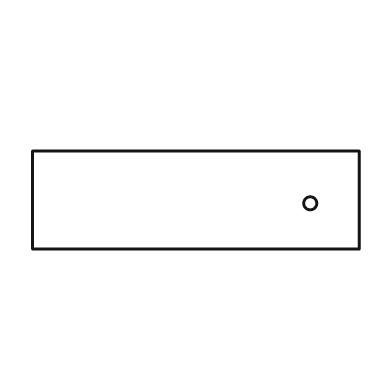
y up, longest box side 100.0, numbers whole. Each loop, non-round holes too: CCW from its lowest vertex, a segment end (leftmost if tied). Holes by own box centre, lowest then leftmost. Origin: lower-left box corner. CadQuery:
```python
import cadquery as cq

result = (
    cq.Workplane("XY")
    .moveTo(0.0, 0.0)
    .lineTo(100.0, 0.0)
    .lineTo(100.0, 30.0)
    .lineTo(0.0, 30.0)
    .close()
    .moveTo(85.0, 14.0)
    .circle(2.0)
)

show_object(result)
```